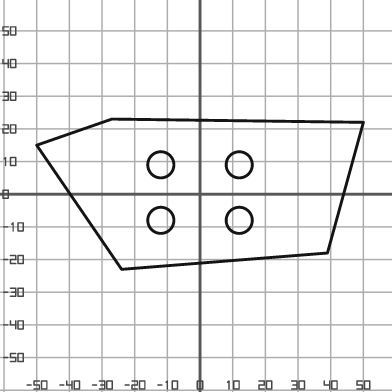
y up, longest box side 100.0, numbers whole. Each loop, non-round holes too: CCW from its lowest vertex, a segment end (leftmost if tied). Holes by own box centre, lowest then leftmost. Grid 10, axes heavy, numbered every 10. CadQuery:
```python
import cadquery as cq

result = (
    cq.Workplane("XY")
    .moveTo(-24.0, -23.0)
    .lineTo(39.0, -18.0)
    .lineTo(50.0, 22.0)
    .lineTo(-27.0, 23.0)
    .lineTo(-50.0, 15.0)
    .close()
    .moveTo(-12.0, -8.0)
    .circle(4.0)
    .moveTo(12.0, -8.0)
    .circle(4.0)
    .moveTo(-12.0, 9.0)
    .circle(4.0)
    .moveTo(12.0, 9.0)
    .circle(4.0)
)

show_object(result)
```